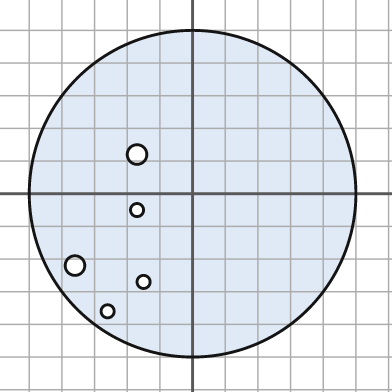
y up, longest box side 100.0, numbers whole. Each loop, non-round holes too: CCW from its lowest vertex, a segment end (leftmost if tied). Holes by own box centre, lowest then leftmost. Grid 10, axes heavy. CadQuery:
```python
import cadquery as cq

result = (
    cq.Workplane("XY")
    .moveTo(0.0, 0.0)
    .circle(50.0)
    .moveTo(-26.0, -36.0)
    .circle(2.0)
    .moveTo(-15.0, -27.0)
    .circle(2.0)
    .moveTo(-36.0, -22.0)
    .circle(3.0)
    .moveTo(-17.0, -5.0)
    .circle(2.0)
    .moveTo(-17.0, 12.0)
    .circle(3.0)
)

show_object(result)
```